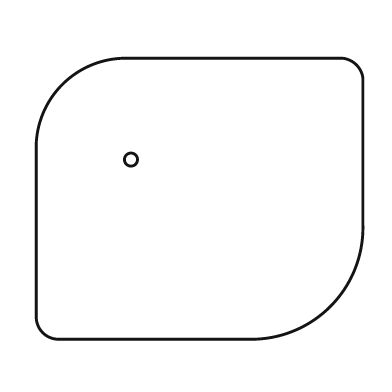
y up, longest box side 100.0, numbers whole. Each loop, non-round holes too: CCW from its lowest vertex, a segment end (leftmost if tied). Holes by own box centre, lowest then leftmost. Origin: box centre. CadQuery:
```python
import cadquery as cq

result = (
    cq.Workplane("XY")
    .moveTo(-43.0, -43.0)
    .lineTo(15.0, -43.0)
    .threePointArc((40.0, -33.0), (50.0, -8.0))
    .lineTo(50.0, 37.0)
    .threePointArc((48.0, 41.0), (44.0, 43.0))
    .lineTo(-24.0, 43.0)
    .threePointArc((-42.0, 35.0), (-50.0, 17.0))
    .lineTo(-50.0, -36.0)
    .threePointArc((-48.0, -41.0), (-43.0, -43.0))
    .close()
    .moveTo(-21.0, 12.0)
    .circle(2.0)
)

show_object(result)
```